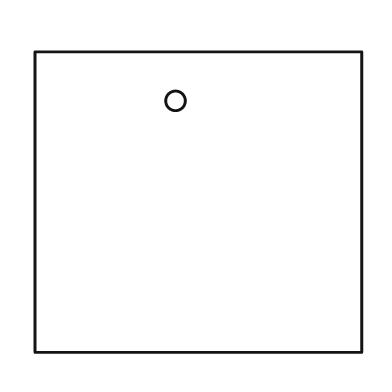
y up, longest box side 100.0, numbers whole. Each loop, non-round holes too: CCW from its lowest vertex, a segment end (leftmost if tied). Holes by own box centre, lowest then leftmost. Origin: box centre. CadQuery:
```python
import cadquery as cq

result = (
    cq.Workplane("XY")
    .moveTo(-50.0, -46.0)
    .lineTo(50.0, -46.0)
    .lineTo(50.0, 46.0)
    .lineTo(-50.0, 46.0)
    .close()
    .moveTo(-7.0, 31.0)
    .circle(3.0)
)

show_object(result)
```